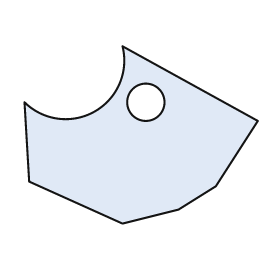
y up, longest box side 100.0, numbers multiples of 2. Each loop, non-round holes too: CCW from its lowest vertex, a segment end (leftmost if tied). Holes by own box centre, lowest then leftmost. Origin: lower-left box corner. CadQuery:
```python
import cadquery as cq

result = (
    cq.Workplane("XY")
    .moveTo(42.0, 0.0)
    .lineTo(66.0, 6.0)
    .lineTo(82.0, 16.0)
    .lineTo(100.0, 44.0)
    .lineTo(42.0, 76.0)
    .threePointArc((30.0, 48.0), (0.0, 52.0))
    .lineTo(2.0, 18.0)
    .close()
    .moveTo(52.0, 52.0)
    .circle(8.0)
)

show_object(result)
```